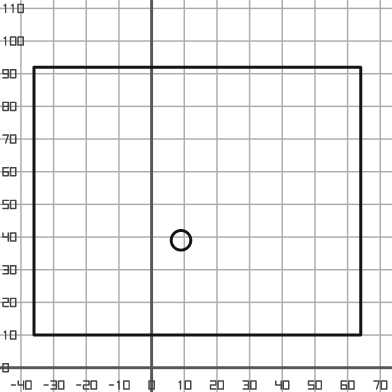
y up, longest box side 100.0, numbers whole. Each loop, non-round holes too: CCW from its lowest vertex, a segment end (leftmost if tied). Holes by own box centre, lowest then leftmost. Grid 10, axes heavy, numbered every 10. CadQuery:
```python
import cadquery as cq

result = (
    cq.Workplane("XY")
    .moveTo(-36.0, 10.0)
    .lineTo(64.0, 10.0)
    .lineTo(64.0, 92.0)
    .lineTo(-36.0, 92.0)
    .close()
    .moveTo(9.0, 39.0)
    .circle(3.0)
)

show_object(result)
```